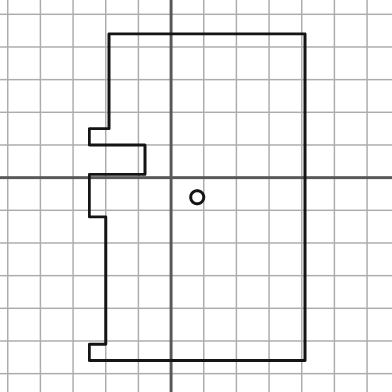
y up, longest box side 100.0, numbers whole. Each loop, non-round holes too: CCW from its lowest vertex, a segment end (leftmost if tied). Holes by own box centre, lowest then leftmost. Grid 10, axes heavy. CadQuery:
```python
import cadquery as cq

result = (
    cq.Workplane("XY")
    .moveTo(-25.0, -56.0)
    .lineTo(41.0, -56.0)
    .lineTo(41.0, 44.0)
    .lineTo(-19.0, 44.0)
    .lineTo(-19.0, 15.0)
    .lineTo(-25.0, 15.0)
    .lineTo(-25.0, 10.0)
    .lineTo(-8.0, 10.0)
    .lineTo(-8.0, 1.0)
    .lineTo(-25.0, 1.0)
    .lineTo(-25.0, -12.0)
    .lineTo(-20.0, -12.0)
    .lineTo(-20.0, -51.0)
    .lineTo(-25.0, -51.0)
    .close()
    .moveTo(8.0, -6.0)
    .circle(2.0)
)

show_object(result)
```